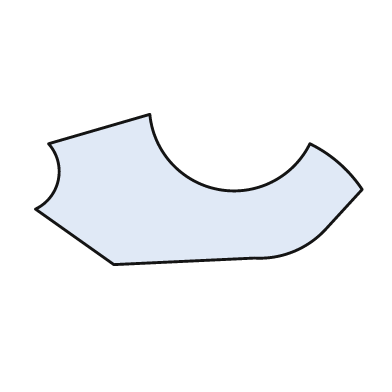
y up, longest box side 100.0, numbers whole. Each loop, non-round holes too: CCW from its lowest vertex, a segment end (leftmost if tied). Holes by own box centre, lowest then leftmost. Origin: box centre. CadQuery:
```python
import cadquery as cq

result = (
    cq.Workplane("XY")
    .moveTo(-26.0, -23.0)
    .lineTo(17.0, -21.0)
    .threePointArc((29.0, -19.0), (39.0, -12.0))
    .lineTo(50.0, 0.0)
    .threePointArc((43.0, 8.0), (34.0, 14.0))
    .threePointArc((6.0, 0.0), (-15.0, 23.0))
    .lineTo(-46.0, 14.0)
    .threePointArc((-43.0, 3.0), (-50.0, -6.0))
    .close()
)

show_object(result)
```